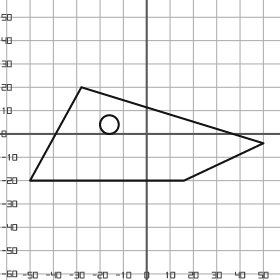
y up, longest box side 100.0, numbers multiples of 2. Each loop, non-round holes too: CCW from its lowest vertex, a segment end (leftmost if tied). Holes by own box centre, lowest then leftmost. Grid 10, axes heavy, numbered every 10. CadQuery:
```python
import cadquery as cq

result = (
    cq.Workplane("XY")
    .moveTo(-50.0, -20.0)
    .lineTo(16.0, -20.0)
    .lineTo(50.0, -4.0)
    .lineTo(-28.0, 20.0)
    .close()
    .moveTo(-16.0, 4.0)
    .circle(4.0)
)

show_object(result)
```